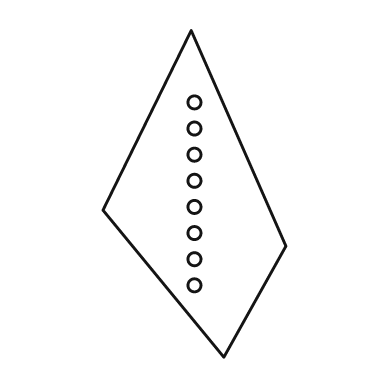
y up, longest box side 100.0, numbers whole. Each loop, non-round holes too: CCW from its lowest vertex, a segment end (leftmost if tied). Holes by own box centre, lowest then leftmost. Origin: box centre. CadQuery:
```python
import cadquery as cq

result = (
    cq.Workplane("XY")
    .moveTo(9.0, -50.0)
    .lineTo(28.0, -16.0)
    .lineTo(-1.0, 50.0)
    .lineTo(-28.0, -5.0)
    .close()
    .moveTo(0.0, -28.0)
    .circle(2.0)
    .moveTo(0.0, -20.0)
    .circle(2.0)
    .moveTo(0.0, -12.0)
    .circle(2.0)
    .moveTo(0.0, -4.0)
    .circle(2.0)
    .moveTo(0.0, 4.0)
    .circle(2.0)
    .moveTo(0.0, 12.0)
    .circle(2.0)
    .moveTo(0.0, 20.0)
    .circle(2.0)
    .moveTo(0.0, 28.0)
    .circle(2.0)
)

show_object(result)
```